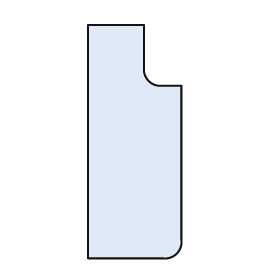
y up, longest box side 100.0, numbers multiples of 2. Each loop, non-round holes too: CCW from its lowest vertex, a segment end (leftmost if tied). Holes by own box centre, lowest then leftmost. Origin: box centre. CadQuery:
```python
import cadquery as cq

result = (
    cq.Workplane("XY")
    .moveTo(-20.0, -50.0)
    .lineTo(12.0, -50.0)
    .threePointArc((18.0, -48.0), (20.0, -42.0))
    .lineTo(20.0, 24.0)
    .lineTo(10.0, 24.0)
    .threePointArc((6.0, 26.0), (4.0, 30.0))
    .lineTo(4.0, 50.0)
    .lineTo(-20.0, 50.0)
    .close()
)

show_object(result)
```